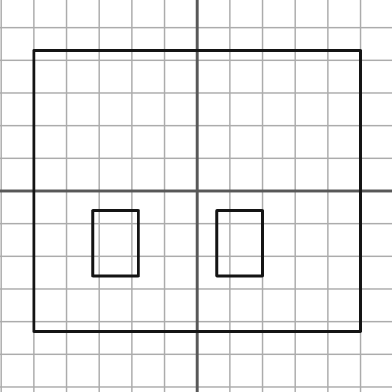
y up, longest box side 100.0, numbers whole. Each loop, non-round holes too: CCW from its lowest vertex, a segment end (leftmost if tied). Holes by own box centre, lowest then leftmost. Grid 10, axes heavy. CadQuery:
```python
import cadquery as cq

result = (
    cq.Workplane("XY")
    .moveTo(-50.0, -43.0)
    .lineTo(50.0, -43.0)
    .lineTo(50.0, 43.0)
    .lineTo(-50.0, 43.0)
    .close()
    .moveTo(-32.0, -26.0)
    .lineTo(-18.0, -26.0)
    .lineTo(-18.0, -6.0)
    .lineTo(-32.0, -6.0)
    .close()
    .moveTo(6.0, -26.0)
    .lineTo(20.0, -26.0)
    .lineTo(20.0, -6.0)
    .lineTo(6.0, -6.0)
    .close()
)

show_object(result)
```